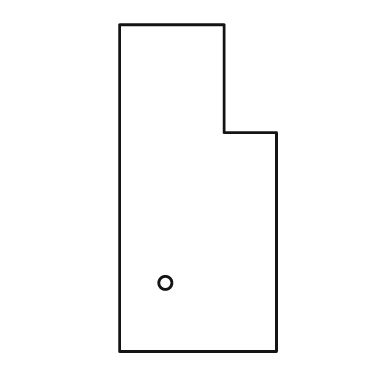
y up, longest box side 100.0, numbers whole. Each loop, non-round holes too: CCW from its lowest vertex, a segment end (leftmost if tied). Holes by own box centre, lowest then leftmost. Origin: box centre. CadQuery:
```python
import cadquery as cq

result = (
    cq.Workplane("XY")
    .moveTo(-24.0, -50.0)
    .lineTo(24.0, -50.0)
    .lineTo(24.0, 17.0)
    .lineTo(8.0, 17.0)
    .lineTo(8.0, 50.0)
    .lineTo(-24.0, 50.0)
    .close()
    .moveTo(-10.0, -29.0)
    .circle(2.0)
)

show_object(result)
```